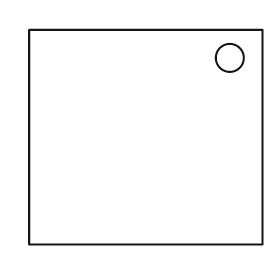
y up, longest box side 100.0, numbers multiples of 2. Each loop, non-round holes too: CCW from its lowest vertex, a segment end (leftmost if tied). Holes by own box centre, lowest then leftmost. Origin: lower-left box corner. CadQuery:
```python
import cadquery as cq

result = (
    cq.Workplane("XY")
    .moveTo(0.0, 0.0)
    .lineTo(100.0, 0.0)
    .lineTo(100.0, 92.0)
    .lineTo(0.0, 92.0)
    .close()
    .moveTo(86.0, 80.0)
    .circle(6.0)
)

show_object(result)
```